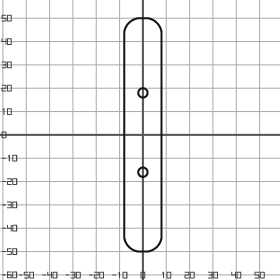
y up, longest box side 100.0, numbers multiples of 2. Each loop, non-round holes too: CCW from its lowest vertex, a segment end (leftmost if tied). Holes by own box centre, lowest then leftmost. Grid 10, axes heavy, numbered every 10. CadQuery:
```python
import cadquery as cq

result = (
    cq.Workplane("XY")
    .moveTo(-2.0, -50.0)
    .lineTo(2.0, -50.0)
    .threePointArc((6.0, -48.0), (8.0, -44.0))
    .lineTo(8.0, 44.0)
    .threePointArc((6.0, 48.0), (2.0, 50.0))
    .lineTo(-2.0, 50.0)
    .threePointArc((-6.0, 48.0), (-8.0, 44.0))
    .lineTo(-8.0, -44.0)
    .threePointArc((-6.0, -48.0), (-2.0, -50.0))
    .close()
    .moveTo(0.0, -16.0)
    .circle(2.0)
    .moveTo(0.0, 18.0)
    .circle(2.0)
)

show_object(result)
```